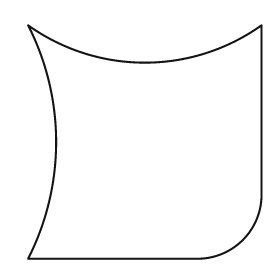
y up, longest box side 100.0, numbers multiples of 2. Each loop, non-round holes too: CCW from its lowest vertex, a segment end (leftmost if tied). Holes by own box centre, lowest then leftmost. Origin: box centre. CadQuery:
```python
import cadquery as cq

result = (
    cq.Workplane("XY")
    .moveTo(-50.0, -50.0)
    .lineTo(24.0, -50.0)
    .threePointArc((42.0, -42.0), (50.0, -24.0))
    .lineTo(50.0, 50.0)
    .threePointArc((0.0, 34.0), (-50.0, 50.0))
    .threePointArc((-38.0, 0.0), (-50.0, -50.0))
    .close()
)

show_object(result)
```